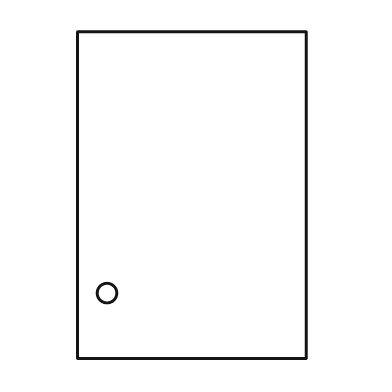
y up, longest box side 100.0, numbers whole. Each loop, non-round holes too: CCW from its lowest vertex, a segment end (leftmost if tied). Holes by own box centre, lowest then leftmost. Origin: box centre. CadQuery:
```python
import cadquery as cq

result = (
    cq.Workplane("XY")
    .moveTo(-35.0, -50.0)
    .lineTo(35.0, -50.0)
    .lineTo(35.0, 50.0)
    .lineTo(-35.0, 50.0)
    .close()
    .moveTo(-26.0, -30.0)
    .circle(3.0)
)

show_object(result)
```